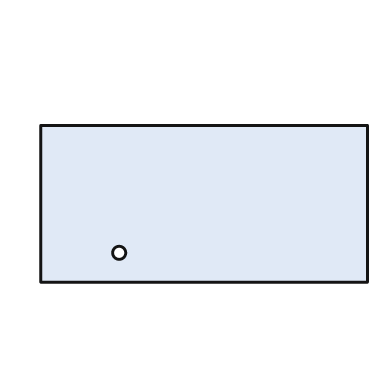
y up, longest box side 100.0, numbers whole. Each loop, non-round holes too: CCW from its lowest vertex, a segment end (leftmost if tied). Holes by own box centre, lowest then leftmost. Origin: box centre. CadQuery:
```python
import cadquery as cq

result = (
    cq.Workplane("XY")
    .moveTo(-50.0, -24.0)
    .lineTo(50.0, -24.0)
    .lineTo(50.0, 24.0)
    .lineTo(-50.0, 24.0)
    .close()
    .moveTo(-26.0, -15.0)
    .circle(2.0)
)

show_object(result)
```